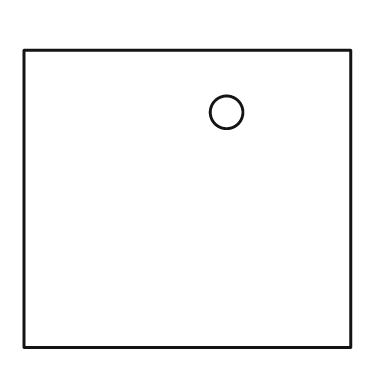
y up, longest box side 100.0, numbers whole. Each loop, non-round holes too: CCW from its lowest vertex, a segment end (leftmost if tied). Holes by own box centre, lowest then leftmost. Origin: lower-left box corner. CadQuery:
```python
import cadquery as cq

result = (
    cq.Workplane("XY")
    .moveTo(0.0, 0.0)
    .lineTo(100.0, 0.0)
    .lineTo(100.0, 91.0)
    .lineTo(0.0, 91.0)
    .close()
    .moveTo(62.0, 72.0)
    .circle(5.0)
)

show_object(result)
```